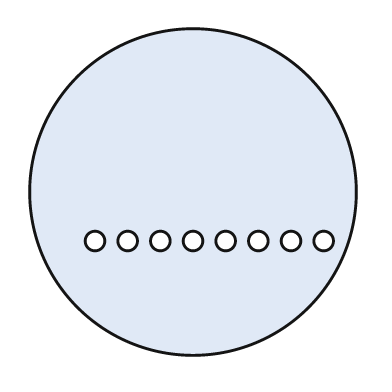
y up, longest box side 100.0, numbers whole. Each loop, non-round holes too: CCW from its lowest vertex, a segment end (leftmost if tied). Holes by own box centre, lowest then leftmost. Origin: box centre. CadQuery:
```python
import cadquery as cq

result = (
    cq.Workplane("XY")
    .moveTo(0.0, 0.0)
    .circle(50.0)
    .moveTo(-30.0, -15.0)
    .circle(3.0)
    .moveTo(-20.0, -15.0)
    .circle(3.0)
    .moveTo(-10.0, -15.0)
    .circle(3.0)
    .moveTo(0.0, -15.0)
    .circle(3.0)
    .moveTo(10.0, -15.0)
    .circle(3.0)
    .moveTo(20.0, -15.0)
    .circle(3.0)
    .moveTo(30.0, -15.0)
    .circle(3.0)
    .moveTo(40.0, -15.0)
    .circle(3.0)
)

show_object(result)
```